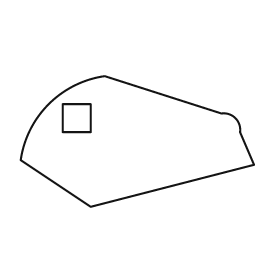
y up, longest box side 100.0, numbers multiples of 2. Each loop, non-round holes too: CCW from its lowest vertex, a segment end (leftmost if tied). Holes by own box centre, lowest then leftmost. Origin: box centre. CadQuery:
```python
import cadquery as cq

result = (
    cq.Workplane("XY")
    .moveTo(-20.0, -28.0)
    .lineTo(50.0, -10.0)
    .lineTo(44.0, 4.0)
    .threePointArc((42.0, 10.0), (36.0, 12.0))
    .lineTo(-14.0, 28.0)
    .threePointArc((-38.0, 16.0), (-50.0, -8.0))
    .close()
    .moveTo(-32.0, 4.0)
    .lineTo(-20.0, 4.0)
    .lineTo(-20.0, 16.0)
    .lineTo(-32.0, 16.0)
    .close()
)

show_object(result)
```